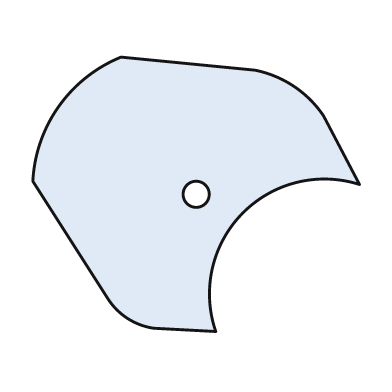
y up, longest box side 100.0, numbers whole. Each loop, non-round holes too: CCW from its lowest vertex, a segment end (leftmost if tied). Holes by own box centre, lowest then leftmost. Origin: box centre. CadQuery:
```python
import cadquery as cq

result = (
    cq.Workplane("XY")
    .moveTo(6.0, -42.0)
    .threePointArc((14.0, -6.0), (50.0, 3.0))
    .lineTo(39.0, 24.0)
    .threePointArc((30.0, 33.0), (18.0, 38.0))
    .lineTo(-23.0, 42.0)
    .threePointArc((-42.0, 27.0), (-50.0, 4.0))
    .lineTo(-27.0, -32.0)
    .threePointArc((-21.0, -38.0), (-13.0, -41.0))
    .close()
    .moveTo(0.0, 0.0)
    .circle(4.0)
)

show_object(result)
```